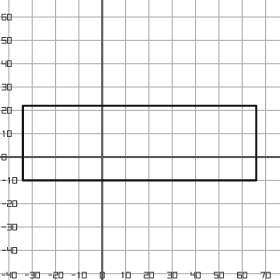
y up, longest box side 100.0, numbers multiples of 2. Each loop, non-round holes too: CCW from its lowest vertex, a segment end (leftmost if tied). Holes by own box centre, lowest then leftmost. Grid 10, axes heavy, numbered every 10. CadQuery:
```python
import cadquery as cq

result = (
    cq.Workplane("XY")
    .moveTo(-34.0, -10.0)
    .lineTo(66.0, -10.0)
    .lineTo(66.0, 22.0)
    .lineTo(-34.0, 22.0)
    .close()
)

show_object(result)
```